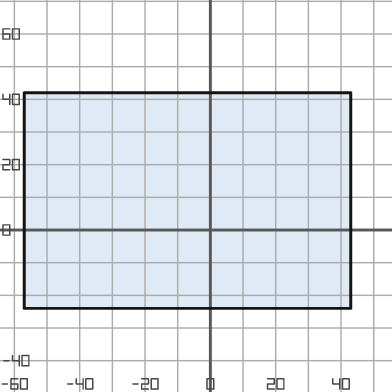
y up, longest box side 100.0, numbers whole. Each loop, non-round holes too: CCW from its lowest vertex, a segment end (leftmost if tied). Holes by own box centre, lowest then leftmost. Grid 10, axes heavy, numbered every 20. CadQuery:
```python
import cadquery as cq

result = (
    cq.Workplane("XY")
    .moveTo(-57.0, -24.0)
    .lineTo(43.0, -24.0)
    .lineTo(43.0, 42.0)
    .lineTo(-57.0, 42.0)
    .close()
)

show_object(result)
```